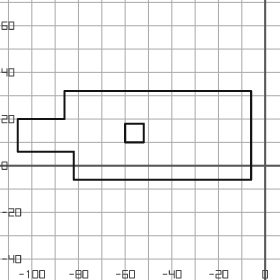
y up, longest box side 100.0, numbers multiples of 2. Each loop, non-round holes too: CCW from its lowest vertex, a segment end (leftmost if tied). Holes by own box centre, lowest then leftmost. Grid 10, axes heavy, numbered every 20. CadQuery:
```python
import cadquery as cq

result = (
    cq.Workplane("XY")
    .moveTo(-82.0, -6.0)
    .lineTo(-6.0, -6.0)
    .lineTo(-6.0, 32.0)
    .lineTo(-86.0, 32.0)
    .lineTo(-86.0, 20.0)
    .lineTo(-106.0, 20.0)
    .lineTo(-106.0, 6.0)
    .lineTo(-82.0, 6.0)
    .close()
    .moveTo(-60.0, 10.0)
    .lineTo(-52.0, 10.0)
    .lineTo(-52.0, 18.0)
    .lineTo(-60.0, 18.0)
    .close()
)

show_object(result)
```